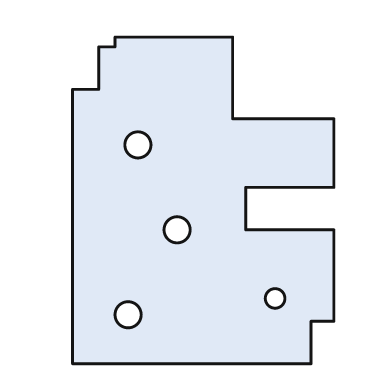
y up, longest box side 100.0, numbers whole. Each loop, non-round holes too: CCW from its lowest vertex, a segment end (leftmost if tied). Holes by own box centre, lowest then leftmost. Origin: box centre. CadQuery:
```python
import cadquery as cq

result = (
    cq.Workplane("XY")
    .moveTo(-40.0, -50.0)
    .lineTo(33.0, -50.0)
    .lineTo(33.0, -37.0)
    .lineTo(40.0, -37.0)
    .lineTo(40.0, -9.0)
    .lineTo(13.0, -9.0)
    .lineTo(13.0, 4.0)
    .lineTo(40.0, 4.0)
    .lineTo(40.0, 25.0)
    .lineTo(9.0, 25.0)
    .lineTo(9.0, 50.0)
    .lineTo(-27.0, 50.0)
    .lineTo(-27.0, 47.0)
    .lineTo(-32.0, 47.0)
    .lineTo(-32.0, 34.0)
    .lineTo(-40.0, 34.0)
    .close()
    .moveTo(-23.0, -35.0)
    .circle(4.0)
    .moveTo(22.0, -30.0)
    .circle(3.0)
    .moveTo(-8.0, -9.0)
    .circle(4.0)
    .moveTo(-20.0, 17.0)
    .circle(4.0)
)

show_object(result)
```